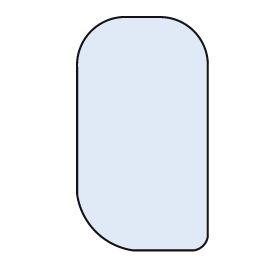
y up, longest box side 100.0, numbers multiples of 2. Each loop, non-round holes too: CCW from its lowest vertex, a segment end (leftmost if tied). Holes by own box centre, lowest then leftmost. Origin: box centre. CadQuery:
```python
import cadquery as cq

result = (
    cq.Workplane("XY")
    .moveTo(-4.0, -50.0)
    .lineTo(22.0, -50.0)
    .threePointArc((26.0, -48.0), (28.0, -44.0))
    .lineTo(28.0, 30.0)
    .threePointArc((22.0, 44.0), (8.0, 50.0))
    .lineTo(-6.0, 50.0)
    .threePointArc((-22.0, 44.0), (-28.0, 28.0))
    .lineTo(-28.0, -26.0)
    .threePointArc((-20.0, -42.0), (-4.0, -50.0))
    .close()
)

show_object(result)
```